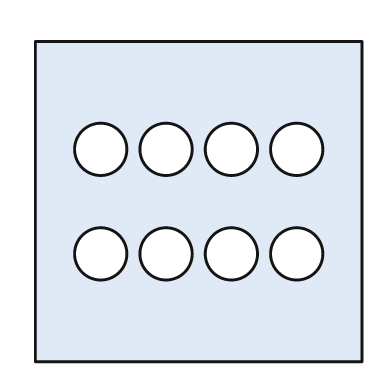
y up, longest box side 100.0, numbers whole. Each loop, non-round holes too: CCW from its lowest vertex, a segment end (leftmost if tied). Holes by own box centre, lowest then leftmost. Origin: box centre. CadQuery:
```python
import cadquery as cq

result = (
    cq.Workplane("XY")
    .moveTo(-50.0, -49.0)
    .lineTo(50.0, -49.0)
    .lineTo(50.0, 49.0)
    .lineTo(-50.0, 49.0)
    .close()
    .moveTo(-30.0, -16.0)
    .circle(8.0)
    .moveTo(-10.0, -16.0)
    .circle(8.0)
    .moveTo(10.0, -16.0)
    .circle(8.0)
    .moveTo(30.0, -16.0)
    .circle(8.0)
    .moveTo(-30.0, 16.0)
    .circle(8.0)
    .moveTo(-10.0, 16.0)
    .circle(8.0)
    .moveTo(10.0, 16.0)
    .circle(8.0)
    .moveTo(30.0, 16.0)
    .circle(8.0)
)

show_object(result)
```